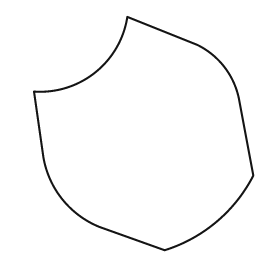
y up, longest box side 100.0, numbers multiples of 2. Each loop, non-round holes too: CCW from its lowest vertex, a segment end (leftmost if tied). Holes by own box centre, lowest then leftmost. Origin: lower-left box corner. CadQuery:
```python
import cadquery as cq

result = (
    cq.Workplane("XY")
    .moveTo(56.0, 0.0)
    .threePointArc((78.0, 12.0), (94.0, 32.0))
    .lineTo(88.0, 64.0)
    .threePointArc((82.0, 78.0), (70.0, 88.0))
    .lineTo(40.0, 100.0)
    .threePointArc((26.0, 76.0), (0.0, 68.0))
    .lineTo(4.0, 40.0)
    .threePointArc((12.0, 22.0), (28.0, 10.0))
    .close()
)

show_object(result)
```